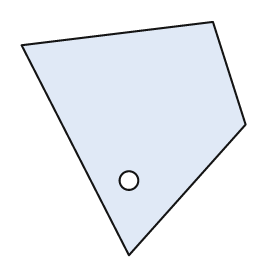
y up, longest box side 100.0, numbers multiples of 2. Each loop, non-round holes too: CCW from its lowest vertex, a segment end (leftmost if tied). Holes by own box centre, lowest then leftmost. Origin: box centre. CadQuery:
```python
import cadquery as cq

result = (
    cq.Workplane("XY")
    .moveTo(-2.0, -50.0)
    .lineTo(48.0, 6.0)
    .lineTo(34.0, 50.0)
    .lineTo(-48.0, 40.0)
    .close()
    .moveTo(-2.0, -18.0)
    .circle(4.0)
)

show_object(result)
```